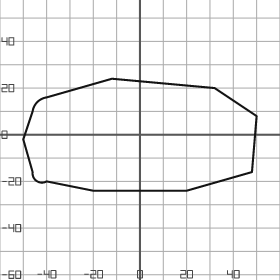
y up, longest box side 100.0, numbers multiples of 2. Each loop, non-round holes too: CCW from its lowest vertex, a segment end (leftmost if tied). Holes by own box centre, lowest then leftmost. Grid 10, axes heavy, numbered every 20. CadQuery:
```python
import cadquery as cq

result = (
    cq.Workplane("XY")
    .moveTo(-20.0, -24.0)
    .lineTo(20.0, -24.0)
    .lineTo(48.0, -16.0)
    .lineTo(50.0, 8.0)
    .lineTo(32.0, 20.0)
    .lineTo(-12.0, 24.0)
    .lineTo(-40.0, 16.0)
    .threePointArc((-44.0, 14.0), (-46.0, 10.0))
    .lineTo(-50.0, -2.0)
    .lineTo(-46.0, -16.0)
    .threePointArc((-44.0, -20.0), (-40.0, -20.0))
    .close()
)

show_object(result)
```